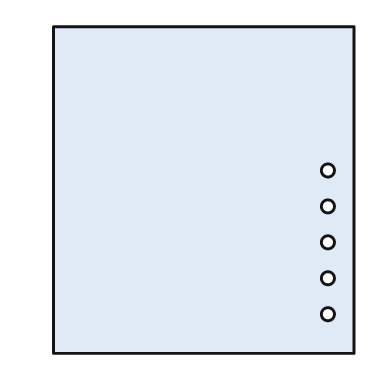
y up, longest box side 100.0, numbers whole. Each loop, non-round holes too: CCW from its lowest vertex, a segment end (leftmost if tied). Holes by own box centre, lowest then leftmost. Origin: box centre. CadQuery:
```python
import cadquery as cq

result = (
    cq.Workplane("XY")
    .moveTo(-46.0, -50.0)
    .lineTo(46.0, -50.0)
    .lineTo(46.0, 50.0)
    .lineTo(-46.0, 50.0)
    .close()
    .moveTo(38.0, -38.0)
    .circle(2.0)
    .moveTo(38.0, -27.0)
    .circle(2.0)
    .moveTo(38.0, -16.0)
    .circle(2.0)
    .moveTo(38.0, -5.0)
    .circle(2.0)
    .moveTo(38.0, 6.0)
    .circle(2.0)
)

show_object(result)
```